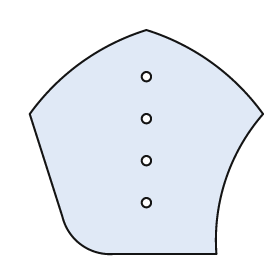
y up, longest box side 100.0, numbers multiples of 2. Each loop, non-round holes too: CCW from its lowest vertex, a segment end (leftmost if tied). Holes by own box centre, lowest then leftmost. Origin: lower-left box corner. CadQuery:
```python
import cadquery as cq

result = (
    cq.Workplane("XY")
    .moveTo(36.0, 0.0)
    .lineTo(80.0, 0.0)
    .threePointArc((84.0, 32.0), (100.0, 60.0))
    .threePointArc((78.0, 82.0), (50.0, 96.0))
    .threePointArc((22.0, 82.0), (0.0, 60.0))
    .lineTo(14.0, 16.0)
    .threePointArc((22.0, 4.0), (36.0, 0.0))
    .close()
    .moveTo(50.0, 22.0)
    .circle(2.0)
    .moveTo(50.0, 40.0)
    .circle(2.0)
    .moveTo(50.0, 58.0)
    .circle(2.0)
    .moveTo(50.0, 76.0)
    .circle(2.0)
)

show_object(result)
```